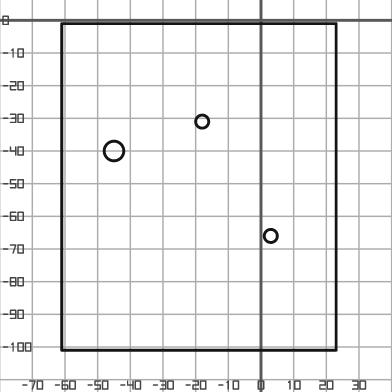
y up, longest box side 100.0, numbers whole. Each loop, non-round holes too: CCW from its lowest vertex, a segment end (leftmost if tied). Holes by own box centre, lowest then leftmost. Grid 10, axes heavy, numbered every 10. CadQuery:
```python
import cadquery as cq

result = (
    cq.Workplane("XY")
    .moveTo(-61.0, -101.0)
    .lineTo(23.0, -101.0)
    .lineTo(23.0, -1.0)
    .lineTo(-61.0, -1.0)
    .close()
    .moveTo(3.0, -66.0)
    .circle(2.0)
    .moveTo(-45.0, -40.0)
    .circle(3.0)
    .moveTo(-18.0, -31.0)
    .circle(2.0)
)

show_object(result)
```